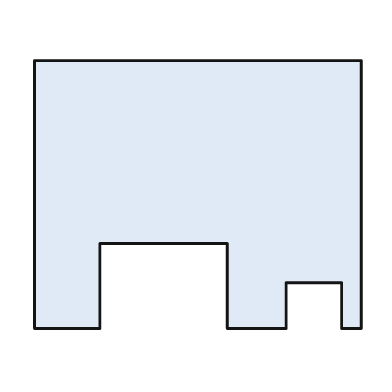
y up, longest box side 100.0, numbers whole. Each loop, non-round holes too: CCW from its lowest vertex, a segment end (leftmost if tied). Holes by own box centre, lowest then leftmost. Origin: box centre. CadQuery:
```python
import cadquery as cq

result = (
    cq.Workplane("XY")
    .moveTo(-50.0, -41.0)
    .lineTo(-30.0, -41.0)
    .lineTo(-30.0, -15.0)
    .lineTo(9.0, -15.0)
    .lineTo(9.0, -41.0)
    .lineTo(27.0, -41.0)
    .lineTo(27.0, -27.0)
    .lineTo(44.0, -27.0)
    .lineTo(44.0, -41.0)
    .lineTo(50.0, -41.0)
    .lineTo(50.0, 41.0)
    .lineTo(-50.0, 41.0)
    .close()
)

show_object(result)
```